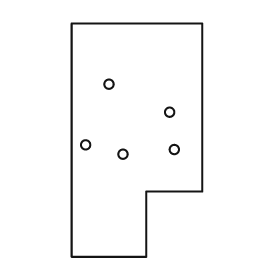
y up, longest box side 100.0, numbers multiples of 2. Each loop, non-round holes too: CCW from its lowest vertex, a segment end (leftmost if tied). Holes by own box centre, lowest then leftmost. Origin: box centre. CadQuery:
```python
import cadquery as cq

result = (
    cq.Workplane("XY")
    .moveTo(-28.0, -50.0)
    .lineTo(4.0, -50.0)
    .lineTo(4.0, -22.0)
    .lineTo(28.0, -22.0)
    .lineTo(28.0, 50.0)
    .lineTo(-28.0, 50.0)
    .close()
    .moveTo(-6.0, -6.0)
    .circle(2.0)
    .moveTo(16.0, -4.0)
    .circle(2.0)
    .moveTo(-22.0, -2.0)
    .circle(2.0)
    .moveTo(14.0, 12.0)
    .circle(2.0)
    .moveTo(-12.0, 24.0)
    .circle(2.0)
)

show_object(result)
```